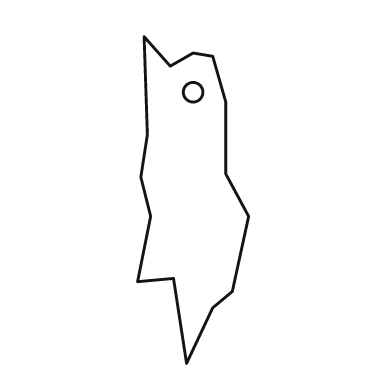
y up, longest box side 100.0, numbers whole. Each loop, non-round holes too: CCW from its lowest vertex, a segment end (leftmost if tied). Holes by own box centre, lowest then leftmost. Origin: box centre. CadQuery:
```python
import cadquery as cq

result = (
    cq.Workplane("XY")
    .moveTo(-2.0, -50.0)
    .lineTo(6.0, -33.0)
    .lineTo(12.0, -28.0)
    .lineTo(17.0, -5.0)
    .lineTo(10.0, 8.0)
    .lineTo(10.0, 30.0)
    .lineTo(6.0, 44.0)
    .lineTo(0.0, 45.0)
    .lineTo(-7.0, 41.0)
    .lineTo(-15.0, 50.0)
    .lineTo(-14.0, 20.0)
    .lineTo(-16.0, 7.0)
    .lineTo(-13.0, -5.0)
    .lineTo(-17.0, -25.0)
    .lineTo(-6.0, -24.0)
    .close()
    .moveTo(0.0, 33.0)
    .circle(3.0)
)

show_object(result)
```